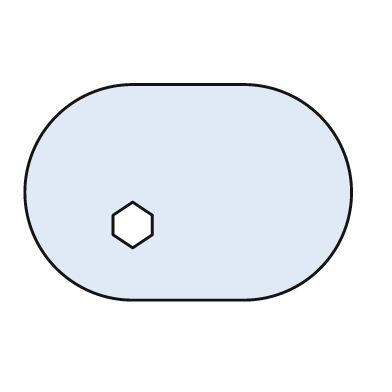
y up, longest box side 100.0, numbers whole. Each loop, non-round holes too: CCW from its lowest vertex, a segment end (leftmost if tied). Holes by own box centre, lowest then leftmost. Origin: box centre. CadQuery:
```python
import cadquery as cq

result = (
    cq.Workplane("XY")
    .moveTo(-17.0, -33.0)
    .lineTo(17.0, -33.0)
    .threePointArc((50.0, 0.0), (17.0, 33.0))
    .lineTo(-17.0, 33.0)
    .threePointArc((-50.0, 0.0), (-17.0, -33.0))
    .close()
    .moveTo(-17.0, -17.0)
    .lineTo(-11.0, -13.0)
    .lineTo(-11.0, -7.0)
    .lineTo(-17.0, -3.0)
    .lineTo(-23.0, -7.0)
    .lineTo(-23.0, -13.0)
    .close()
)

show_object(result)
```